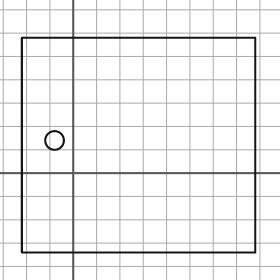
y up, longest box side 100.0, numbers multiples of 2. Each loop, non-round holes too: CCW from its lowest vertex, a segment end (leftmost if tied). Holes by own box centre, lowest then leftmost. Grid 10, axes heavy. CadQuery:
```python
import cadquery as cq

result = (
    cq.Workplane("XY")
    .moveTo(-22.0, -34.0)
    .lineTo(78.0, -34.0)
    .lineTo(78.0, 58.0)
    .lineTo(-22.0, 58.0)
    .close()
    .moveTo(-8.0, 14.0)
    .circle(4.0)
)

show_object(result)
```